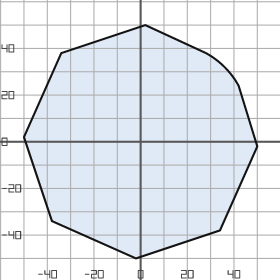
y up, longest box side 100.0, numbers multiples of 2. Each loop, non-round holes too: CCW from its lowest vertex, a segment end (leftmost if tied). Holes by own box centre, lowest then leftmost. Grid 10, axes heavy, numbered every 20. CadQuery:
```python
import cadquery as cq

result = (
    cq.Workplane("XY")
    .moveTo(-2.0, -50.0)
    .lineTo(34.0, -38.0)
    .lineTo(50.0, -2.0)
    .lineTo(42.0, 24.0)
    .threePointArc((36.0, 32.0), (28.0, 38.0))
    .lineTo(2.0, 50.0)
    .lineTo(-34.0, 38.0)
    .lineTo(-50.0, 2.0)
    .lineTo(-38.0, -34.0)
    .close()
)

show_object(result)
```